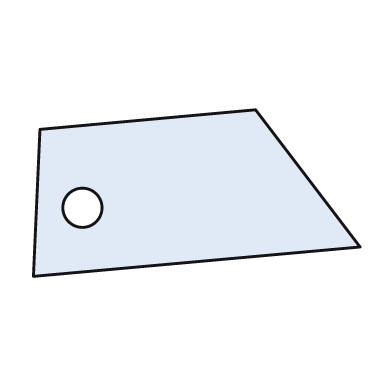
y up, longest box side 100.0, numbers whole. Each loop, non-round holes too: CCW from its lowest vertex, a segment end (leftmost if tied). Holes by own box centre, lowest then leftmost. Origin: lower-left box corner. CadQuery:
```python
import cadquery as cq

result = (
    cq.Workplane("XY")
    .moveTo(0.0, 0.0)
    .lineTo(100.0, 9.0)
    .lineTo(68.0, 51.0)
    .lineTo(2.0, 45.0)
    .close()
    .moveTo(15.0, 21.0)
    .circle(6.0)
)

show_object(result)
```